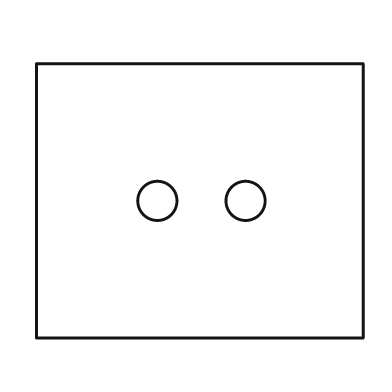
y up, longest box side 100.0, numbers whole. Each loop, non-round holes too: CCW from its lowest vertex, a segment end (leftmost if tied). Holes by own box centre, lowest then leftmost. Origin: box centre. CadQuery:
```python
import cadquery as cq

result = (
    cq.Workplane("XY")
    .moveTo(-50.0, -42.0)
    .lineTo(50.0, -42.0)
    .lineTo(50.0, 42.0)
    .lineTo(-50.0, 42.0)
    .close()
    .moveTo(-13.0, 0.0)
    .circle(6.0)
    .moveTo(14.0, 0.0)
    .circle(6.0)
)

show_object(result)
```